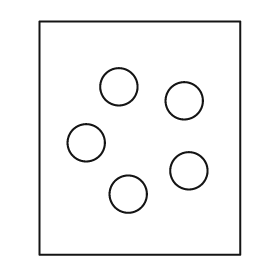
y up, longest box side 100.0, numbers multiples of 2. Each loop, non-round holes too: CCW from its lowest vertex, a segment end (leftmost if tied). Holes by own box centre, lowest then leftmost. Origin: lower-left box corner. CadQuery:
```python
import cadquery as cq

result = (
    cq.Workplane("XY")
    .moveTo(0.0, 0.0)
    .lineTo(86.0, 0.0)
    .lineTo(86.0, 100.0)
    .lineTo(0.0, 100.0)
    .close()
    .moveTo(38.0, 26.0)
    .circle(8.0)
    .moveTo(64.0, 36.0)
    .circle(8.0)
    .moveTo(20.0, 48.0)
    .circle(8.0)
    .moveTo(62.0, 66.0)
    .circle(8.0)
    .moveTo(34.0, 72.0)
    .circle(8.0)
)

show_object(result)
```